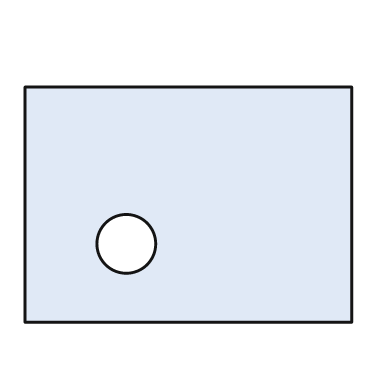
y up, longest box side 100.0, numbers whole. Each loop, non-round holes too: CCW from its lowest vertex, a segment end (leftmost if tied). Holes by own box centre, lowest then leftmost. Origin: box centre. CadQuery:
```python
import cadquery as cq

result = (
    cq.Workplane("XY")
    .moveTo(-50.0, -36.0)
    .lineTo(50.0, -36.0)
    .lineTo(50.0, 36.0)
    .lineTo(-50.0, 36.0)
    .close()
    .moveTo(-19.0, -12.0)
    .circle(9.0)
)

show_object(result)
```